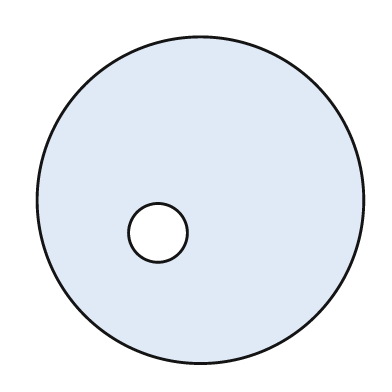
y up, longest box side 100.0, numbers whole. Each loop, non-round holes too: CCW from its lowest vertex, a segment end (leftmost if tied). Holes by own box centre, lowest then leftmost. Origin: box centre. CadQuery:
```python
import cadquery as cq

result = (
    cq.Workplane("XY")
    .moveTo(0.0, 0.0)
    .circle(50.0)
    .moveTo(-13.0, -10.0)
    .circle(9.0)
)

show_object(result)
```